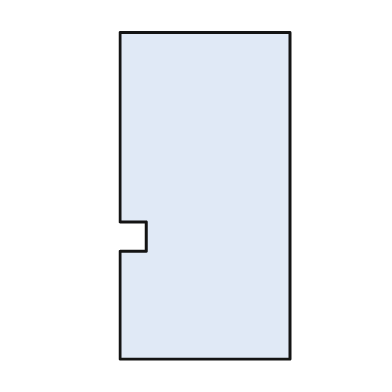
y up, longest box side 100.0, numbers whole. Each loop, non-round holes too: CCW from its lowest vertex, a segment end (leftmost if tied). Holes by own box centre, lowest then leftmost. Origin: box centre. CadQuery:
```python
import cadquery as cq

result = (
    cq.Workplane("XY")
    .moveTo(-26.0, -50.0)
    .lineTo(26.0, -50.0)
    .lineTo(26.0, 50.0)
    .lineTo(-26.0, 50.0)
    .lineTo(-26.0, -8.0)
    .lineTo(-18.0, -8.0)
    .lineTo(-18.0, -17.0)
    .lineTo(-26.0, -17.0)
    .close()
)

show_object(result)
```